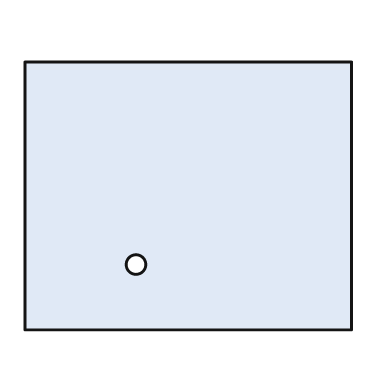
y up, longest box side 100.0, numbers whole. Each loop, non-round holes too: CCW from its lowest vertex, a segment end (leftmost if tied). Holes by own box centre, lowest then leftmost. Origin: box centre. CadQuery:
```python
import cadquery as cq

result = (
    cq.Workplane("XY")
    .moveTo(-50.0, -41.0)
    .lineTo(50.0, -41.0)
    .lineTo(50.0, 41.0)
    .lineTo(-50.0, 41.0)
    .close()
    .moveTo(-16.0, -21.0)
    .circle(3.0)
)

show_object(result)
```